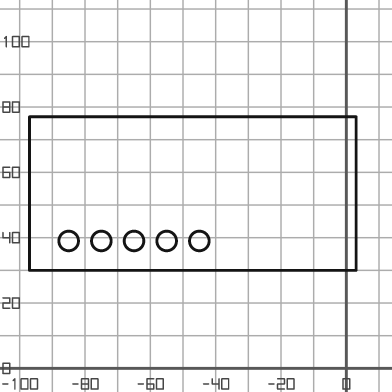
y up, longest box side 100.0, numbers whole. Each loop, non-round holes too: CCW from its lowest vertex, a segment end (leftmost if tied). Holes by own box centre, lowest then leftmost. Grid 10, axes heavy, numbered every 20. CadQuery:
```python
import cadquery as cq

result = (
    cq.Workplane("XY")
    .moveTo(-97.0, 30.0)
    .lineTo(3.0, 30.0)
    .lineTo(3.0, 77.0)
    .lineTo(-97.0, 77.0)
    .close()
    .moveTo(-85.0, 39.0)
    .circle(3.0)
    .moveTo(-75.0, 39.0)
    .circle(3.0)
    .moveTo(-65.0, 39.0)
    .circle(3.0)
    .moveTo(-55.0, 39.0)
    .circle(3.0)
    .moveTo(-45.0, 39.0)
    .circle(3.0)
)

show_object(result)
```